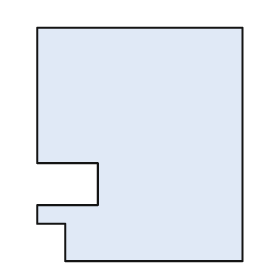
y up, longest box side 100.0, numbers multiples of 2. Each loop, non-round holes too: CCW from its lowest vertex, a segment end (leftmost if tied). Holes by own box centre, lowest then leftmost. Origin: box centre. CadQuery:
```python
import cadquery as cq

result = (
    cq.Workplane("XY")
    .moveTo(-32.0, -50.0)
    .lineTo(44.0, -50.0)
    .lineTo(44.0, 50.0)
    .lineTo(-44.0, 50.0)
    .lineTo(-44.0, -8.0)
    .lineTo(-18.0, -8.0)
    .lineTo(-18.0, -26.0)
    .lineTo(-44.0, -26.0)
    .lineTo(-44.0, -34.0)
    .lineTo(-32.0, -34.0)
    .close()
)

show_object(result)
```